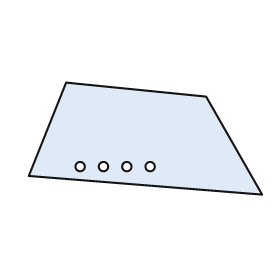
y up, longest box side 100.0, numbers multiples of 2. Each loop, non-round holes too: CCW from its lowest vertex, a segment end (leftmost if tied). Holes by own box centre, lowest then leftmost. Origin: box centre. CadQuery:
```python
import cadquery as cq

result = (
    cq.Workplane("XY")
    .moveTo(50.0, -24.0)
    .lineTo(26.0, 18.0)
    .lineTo(-34.0, 24.0)
    .lineTo(-50.0, -16.0)
    .close()
    .moveTo(-28.0, -12.0)
    .circle(2.0)
    .moveTo(-18.0, -12.0)
    .circle(2.0)
    .moveTo(-8.0, -12.0)
    .circle(2.0)
    .moveTo(2.0, -12.0)
    .circle(2.0)
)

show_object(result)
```